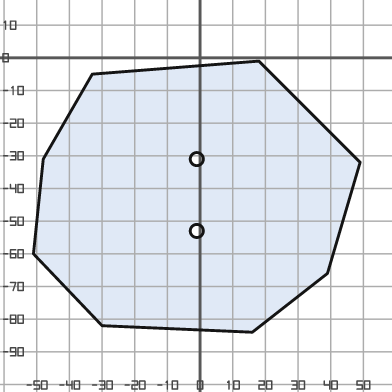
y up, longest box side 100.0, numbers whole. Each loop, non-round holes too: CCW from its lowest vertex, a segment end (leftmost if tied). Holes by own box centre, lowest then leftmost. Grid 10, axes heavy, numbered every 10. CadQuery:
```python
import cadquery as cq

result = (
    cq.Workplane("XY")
    .moveTo(16.0, -84.0)
    .lineTo(39.0, -66.0)
    .lineTo(49.0, -32.0)
    .lineTo(18.0, -1.0)
    .lineTo(-33.0, -5.0)
    .lineTo(-48.0, -31.0)
    .lineTo(-51.0, -60.0)
    .lineTo(-30.0, -82.0)
    .close()
    .moveTo(-1.0, -53.0)
    .circle(2.0)
    .moveTo(-1.0, -31.0)
    .circle(2.0)
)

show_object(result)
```